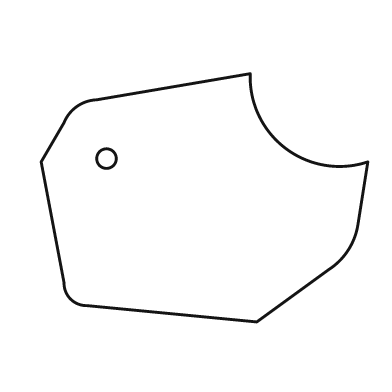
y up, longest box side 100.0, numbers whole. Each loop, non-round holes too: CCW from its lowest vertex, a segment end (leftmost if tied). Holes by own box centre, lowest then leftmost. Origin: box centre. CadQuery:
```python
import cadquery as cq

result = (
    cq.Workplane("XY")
    .moveTo(16.0, -38.0)
    .lineTo(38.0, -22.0)
    .threePointArc((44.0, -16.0), (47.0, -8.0))
    .lineTo(50.0, 11.0)
    .threePointArc((25.0, 15.0), (14.0, 38.0))
    .lineTo(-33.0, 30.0)
    .threePointArc((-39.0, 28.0), (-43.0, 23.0))
    .lineTo(-50.0, 11.0)
    .lineTo(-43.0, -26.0)
    .threePointArc((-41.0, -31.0), (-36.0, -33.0))
    .close()
    .moveTo(-30.0, 12.0)
    .circle(3.0)
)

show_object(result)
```